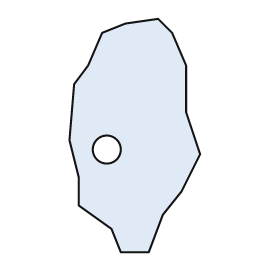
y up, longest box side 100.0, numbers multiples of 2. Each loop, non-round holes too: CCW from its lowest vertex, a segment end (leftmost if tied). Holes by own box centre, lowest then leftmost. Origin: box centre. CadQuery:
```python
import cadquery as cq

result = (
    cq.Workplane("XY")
    .moveTo(-6.0, -50.0)
    .lineTo(6.0, -50.0)
    .lineTo(12.0, -34.0)
    .lineTo(20.0, -24.0)
    .lineTo(28.0, -8.0)
    .lineTo(22.0, 10.0)
    .lineTo(22.0, 30.0)
    .lineTo(16.0, 44.0)
    .lineTo(10.0, 50.0)
    .lineTo(-4.0, 48.0)
    .lineTo(-14.0, 44.0)
    .lineTo(-20.0, 30.0)
    .lineTo(-26.0, 22.0)
    .lineTo(-28.0, -2.0)
    .lineTo(-24.0, -18.0)
    .lineTo(-24.0, -30.0)
    .lineTo(-10.0, -40.0)
    .close()
    .moveTo(-12.0, -6.0)
    .circle(6.0)
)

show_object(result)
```